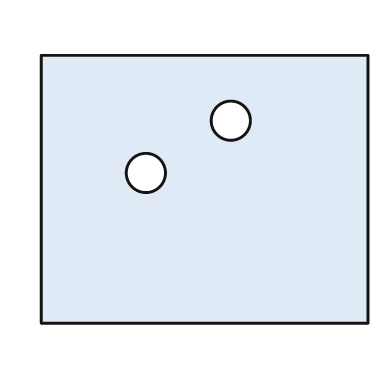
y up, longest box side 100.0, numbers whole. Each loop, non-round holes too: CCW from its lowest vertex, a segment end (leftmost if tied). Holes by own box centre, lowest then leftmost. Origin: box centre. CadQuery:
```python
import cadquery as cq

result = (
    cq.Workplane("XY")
    .moveTo(-50.0, -41.0)
    .lineTo(50.0, -41.0)
    .lineTo(50.0, 41.0)
    .lineTo(-50.0, 41.0)
    .close()
    .moveTo(-18.0, 5.0)
    .circle(6.0)
    .moveTo(8.0, 21.0)
    .circle(6.0)
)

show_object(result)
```